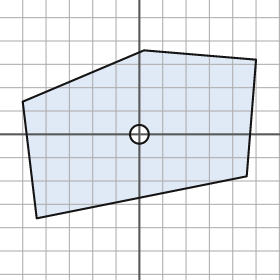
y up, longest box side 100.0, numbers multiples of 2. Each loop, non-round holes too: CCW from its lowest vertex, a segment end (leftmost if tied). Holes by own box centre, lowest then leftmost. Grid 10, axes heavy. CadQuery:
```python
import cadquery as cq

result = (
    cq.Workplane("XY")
    .moveTo(-44.0, -36.0)
    .lineTo(46.0, -18.0)
    .lineTo(50.0, 32.0)
    .lineTo(2.0, 36.0)
    .lineTo(-50.0, 14.0)
    .close()
    .moveTo(0.0, 0.0)
    .circle(4.0)
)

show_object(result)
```